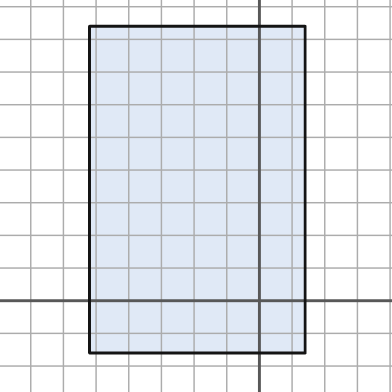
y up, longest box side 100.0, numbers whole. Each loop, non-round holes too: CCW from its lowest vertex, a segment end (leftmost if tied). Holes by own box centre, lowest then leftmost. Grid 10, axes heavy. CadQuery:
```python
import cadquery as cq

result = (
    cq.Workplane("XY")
    .moveTo(-52.0, -16.0)
    .lineTo(14.0, -16.0)
    .lineTo(14.0, 84.0)
    .lineTo(-52.0, 84.0)
    .close()
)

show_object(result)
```